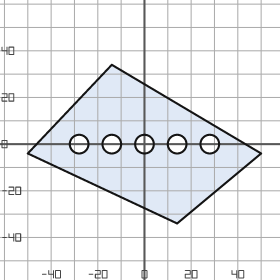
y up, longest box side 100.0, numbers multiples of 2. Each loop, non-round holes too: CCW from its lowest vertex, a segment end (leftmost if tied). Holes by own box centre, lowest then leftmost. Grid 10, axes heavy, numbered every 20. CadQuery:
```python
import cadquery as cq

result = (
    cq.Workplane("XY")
    .moveTo(14.0, -34.0)
    .lineTo(50.0, -4.0)
    .lineTo(-14.0, 34.0)
    .lineTo(-50.0, -4.0)
    .close()
    .moveTo(-28.0, 0.0)
    .circle(4.0)
    .moveTo(-14.0, 0.0)
    .circle(4.0)
    .moveTo(0.0, 0.0)
    .circle(4.0)
    .moveTo(14.0, 0.0)
    .circle(4.0)
    .moveTo(28.0, 0.0)
    .circle(4.0)
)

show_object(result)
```